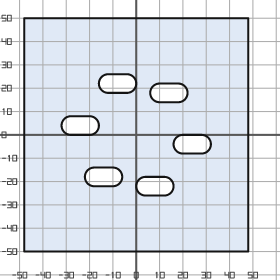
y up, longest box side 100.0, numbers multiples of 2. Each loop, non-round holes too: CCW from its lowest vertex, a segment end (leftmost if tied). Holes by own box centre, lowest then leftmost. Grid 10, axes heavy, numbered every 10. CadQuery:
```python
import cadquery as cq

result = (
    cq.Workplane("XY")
    .moveTo(-48.0, -50.0)
    .lineTo(48.0, -50.0)
    .lineTo(48.0, 50.0)
    .lineTo(-48.0, 50.0)
    .close()
    .moveTo(4.0, -26.0)
    .lineTo(12.0, -26.0)
    .threePointArc((16.0, -22.0), (12.0, -18.0))
    .lineTo(4.0, -18.0)
    .threePointArc((0.0, -22.0), (4.0, -26.0))
    .close()
    .moveTo(-18.0, -22.0)
    .lineTo(-10.0, -22.0)
    .threePointArc((-6.0, -18.0), (-10.0, -14.0))
    .lineTo(-18.0, -14.0)
    .threePointArc((-22.0, -18.0), (-18.0, -22.0))
    .close()
    .moveTo(20.0, -8.0)
    .lineTo(28.0, -8.0)
    .threePointArc((32.0, -4.0), (28.0, 0.0))
    .lineTo(20.0, 0.0)
    .threePointArc((16.0, -4.0), (20.0, -8.0))
    .close()
    .moveTo(-28.0, 0.0)
    .lineTo(-20.0, 0.0)
    .threePointArc((-16.0, 4.0), (-20.0, 8.0))
    .lineTo(-28.0, 8.0)
    .threePointArc((-32.0, 4.0), (-28.0, 0.0))
    .close()
    .moveTo(10.0, 14.0)
    .lineTo(18.0, 14.0)
    .threePointArc((22.0, 18.0), (18.0, 22.0))
    .lineTo(10.0, 22.0)
    .threePointArc((6.0, 18.0), (10.0, 14.0))
    .close()
    .moveTo(-12.0, 18.0)
    .lineTo(-4.0, 18.0)
    .threePointArc((0.0, 22.0), (-4.0, 26.0))
    .lineTo(-12.0, 26.0)
    .threePointArc((-16.0, 22.0), (-12.0, 18.0))
    .close()
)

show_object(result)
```